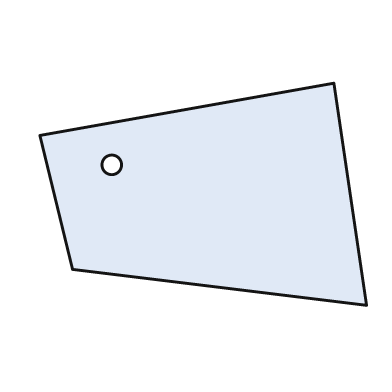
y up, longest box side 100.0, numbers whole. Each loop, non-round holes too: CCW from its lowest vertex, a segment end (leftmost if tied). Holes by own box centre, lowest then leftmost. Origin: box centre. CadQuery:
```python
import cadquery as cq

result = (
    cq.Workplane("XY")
    .moveTo(50.0, -34.0)
    .lineTo(40.0, 34.0)
    .lineTo(-50.0, 18.0)
    .lineTo(-40.0, -23.0)
    .close()
    .moveTo(-28.0, 9.0)
    .circle(3.0)
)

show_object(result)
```